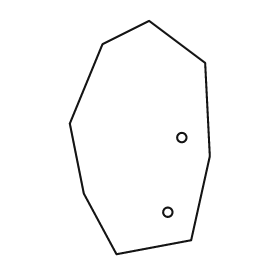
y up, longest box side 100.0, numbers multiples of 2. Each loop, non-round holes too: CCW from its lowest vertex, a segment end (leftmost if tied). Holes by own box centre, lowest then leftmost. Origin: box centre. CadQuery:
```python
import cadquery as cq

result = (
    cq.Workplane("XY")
    .moveTo(-10.0, -50.0)
    .lineTo(22.0, -44.0)
    .lineTo(30.0, -8.0)
    .lineTo(28.0, 32.0)
    .lineTo(4.0, 50.0)
    .lineTo(-16.0, 40.0)
    .lineTo(-30.0, 6.0)
    .lineTo(-24.0, -24.0)
    .close()
    .moveTo(12.0, -32.0)
    .circle(2.0)
    .moveTo(18.0, 0.0)
    .circle(2.0)
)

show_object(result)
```